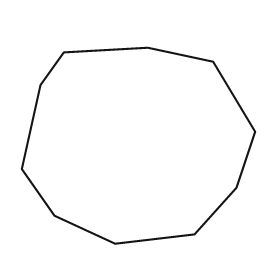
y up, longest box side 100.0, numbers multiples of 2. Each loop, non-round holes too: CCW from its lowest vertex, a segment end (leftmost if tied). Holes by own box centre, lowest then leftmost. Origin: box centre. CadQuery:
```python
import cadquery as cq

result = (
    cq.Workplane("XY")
    .moveTo(-10.0, -42.0)
    .lineTo(24.0, -38.0)
    .lineTo(42.0, -18.0)
    .lineTo(50.0, 6.0)
    .lineTo(32.0, 36.0)
    .lineTo(4.0, 42.0)
    .lineTo(-32.0, 40.0)
    .lineTo(-42.0, 26.0)
    .lineTo(-50.0, -10.0)
    .lineTo(-36.0, -30.0)
    .close()
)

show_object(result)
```